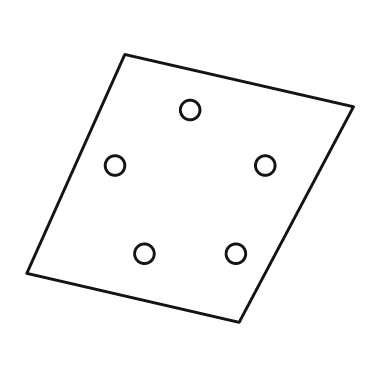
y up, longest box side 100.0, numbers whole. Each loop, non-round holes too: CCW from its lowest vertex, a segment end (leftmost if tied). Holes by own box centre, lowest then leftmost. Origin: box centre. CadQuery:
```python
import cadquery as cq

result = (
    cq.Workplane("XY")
    .moveTo(15.0, -41.0)
    .lineTo(50.0, 25.0)
    .lineTo(-20.0, 41.0)
    .lineTo(-50.0, -26.0)
    .close()
    .moveTo(-14.0, -20.0)
    .circle(3.0)
    .moveTo(14.0, -20.0)
    .circle(3.0)
    .moveTo(-23.0, 7.0)
    .circle(3.0)
    .moveTo(23.0, 7.0)
    .circle(3.0)
    .moveTo(0.0, 24.0)
    .circle(3.0)
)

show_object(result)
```